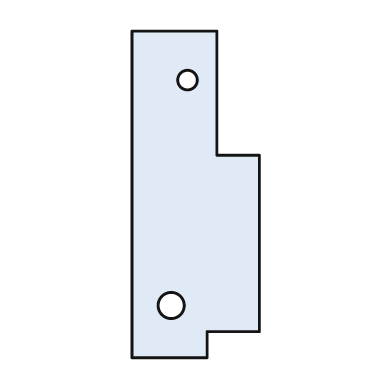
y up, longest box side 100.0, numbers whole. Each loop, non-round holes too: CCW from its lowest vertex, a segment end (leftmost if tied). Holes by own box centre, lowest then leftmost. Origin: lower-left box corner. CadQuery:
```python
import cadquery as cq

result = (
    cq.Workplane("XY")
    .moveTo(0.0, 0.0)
    .lineTo(23.0, 0.0)
    .lineTo(23.0, 8.0)
    .lineTo(39.0, 8.0)
    .lineTo(39.0, 62.0)
    .lineTo(26.0, 62.0)
    .lineTo(26.0, 100.0)
    .lineTo(0.0, 100.0)
    .close()
    .moveTo(12.0, 16.0)
    .circle(4.0)
    .moveTo(17.0, 85.0)
    .circle(3.0)
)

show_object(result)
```